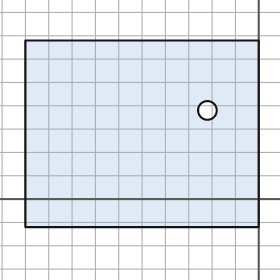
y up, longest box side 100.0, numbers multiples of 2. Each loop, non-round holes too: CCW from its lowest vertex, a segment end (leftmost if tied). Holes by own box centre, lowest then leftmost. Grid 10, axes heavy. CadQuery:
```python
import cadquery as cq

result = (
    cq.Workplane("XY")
    .moveTo(-100.0, -12.0)
    .lineTo(0.0, -12.0)
    .lineTo(0.0, 68.0)
    .lineTo(-100.0, 68.0)
    .close()
    .moveTo(-22.0, 38.0)
    .circle(4.0)
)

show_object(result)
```